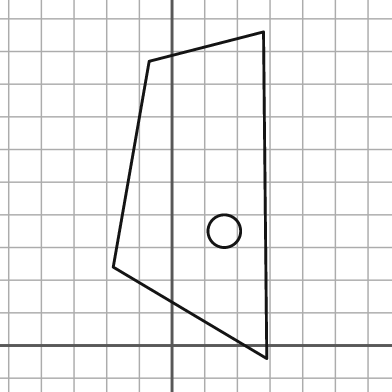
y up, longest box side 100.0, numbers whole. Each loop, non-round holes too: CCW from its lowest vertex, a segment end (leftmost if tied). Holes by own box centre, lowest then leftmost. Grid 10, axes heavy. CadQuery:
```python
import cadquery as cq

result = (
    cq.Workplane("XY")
    .moveTo(29.0, -4.0)
    .lineTo(28.0, 96.0)
    .lineTo(-7.0, 87.0)
    .lineTo(-18.0, 24.0)
    .close()
    .moveTo(16.0, 35.0)
    .circle(5.0)
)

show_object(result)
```